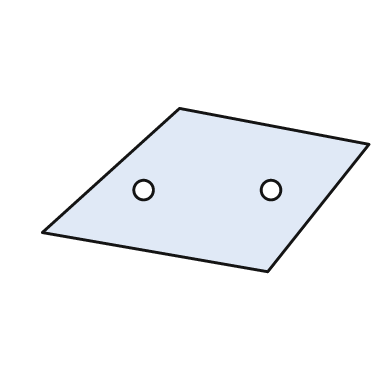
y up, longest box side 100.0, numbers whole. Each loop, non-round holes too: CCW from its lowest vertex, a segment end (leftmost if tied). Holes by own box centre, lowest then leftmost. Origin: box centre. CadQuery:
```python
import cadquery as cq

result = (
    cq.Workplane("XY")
    .moveTo(19.0, -25.0)
    .lineTo(50.0, 14.0)
    .lineTo(-8.0, 25.0)
    .lineTo(-50.0, -13.0)
    .close()
    .moveTo(-19.0, 0.0)
    .circle(3.0)
    .moveTo(20.0, 0.0)
    .circle(3.0)
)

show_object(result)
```